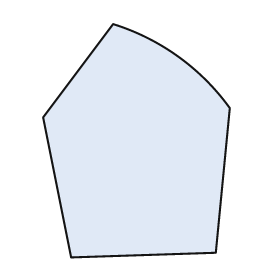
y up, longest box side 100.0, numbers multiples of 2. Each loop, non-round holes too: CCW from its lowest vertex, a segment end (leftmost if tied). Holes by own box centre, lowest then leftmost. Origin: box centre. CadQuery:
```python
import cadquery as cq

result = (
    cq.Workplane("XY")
    .moveTo(-28.0, -50.0)
    .lineTo(34.0, -48.0)
    .lineTo(40.0, 14.0)
    .threePointArc((18.0, 36.0), (-10.0, 50.0))
    .lineTo(-40.0, 10.0)
    .close()
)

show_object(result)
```